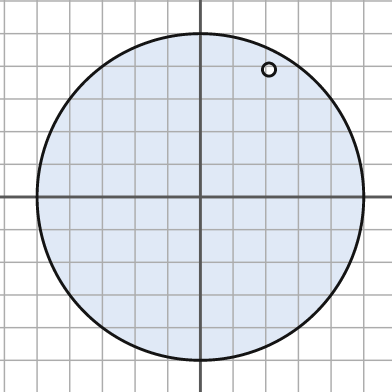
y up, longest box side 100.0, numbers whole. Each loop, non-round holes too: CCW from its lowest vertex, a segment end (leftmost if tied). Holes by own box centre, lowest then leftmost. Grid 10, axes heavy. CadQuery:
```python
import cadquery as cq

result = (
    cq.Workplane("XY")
    .moveTo(0.0, 0.0)
    .circle(50.0)
    .moveTo(21.0, 39.0)
    .circle(2.0)
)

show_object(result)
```